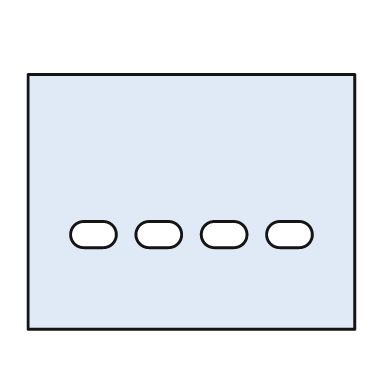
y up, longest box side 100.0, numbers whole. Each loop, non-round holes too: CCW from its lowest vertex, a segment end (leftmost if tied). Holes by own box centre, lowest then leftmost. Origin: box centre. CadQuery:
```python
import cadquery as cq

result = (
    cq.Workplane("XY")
    .moveTo(-50.0, -39.0)
    .lineTo(50.0, -39.0)
    .lineTo(50.0, 39.0)
    .lineTo(-50.0, 39.0)
    .close()
    .moveTo(-33.0, -14.0)
    .lineTo(-27.0, -14.0)
    .threePointArc((-23.0, -10.0), (-27.0, -6.0))
    .lineTo(-33.0, -6.0)
    .threePointArc((-37.0, -10.0), (-33.0, -14.0))
    .close()
    .moveTo(-13.0, -14.0)
    .lineTo(-7.0, -14.0)
    .threePointArc((-3.0, -10.0), (-7.0, -6.0))
    .lineTo(-13.0, -6.0)
    .threePointArc((-17.0, -10.0), (-13.0, -14.0))
    .close()
    .moveTo(7.0, -14.0)
    .lineTo(13.0, -14.0)
    .threePointArc((17.0, -10.0), (13.0, -6.0))
    .lineTo(7.0, -6.0)
    .threePointArc((3.0, -10.0), (7.0, -14.0))
    .close()
    .moveTo(27.0, -14.0)
    .lineTo(33.0, -14.0)
    .threePointArc((37.0, -10.0), (33.0, -6.0))
    .lineTo(27.0, -6.0)
    .threePointArc((23.0, -10.0), (27.0, -14.0))
    .close()
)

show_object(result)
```